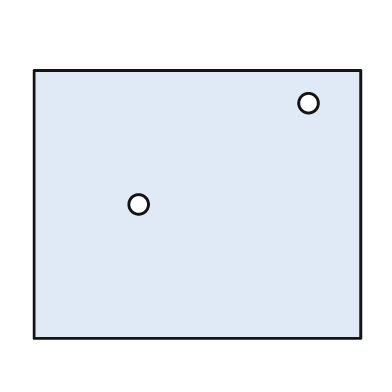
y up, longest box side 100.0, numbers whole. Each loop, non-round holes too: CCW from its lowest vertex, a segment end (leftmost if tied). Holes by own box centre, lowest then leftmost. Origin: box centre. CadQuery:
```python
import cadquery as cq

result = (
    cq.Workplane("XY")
    .moveTo(-50.0, -41.0)
    .lineTo(50.0, -41.0)
    .lineTo(50.0, 41.0)
    .lineTo(-50.0, 41.0)
    .close()
    .moveTo(-18.0, 0.0)
    .circle(3.0)
    .moveTo(34.0, 31.0)
    .circle(3.0)
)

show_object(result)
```